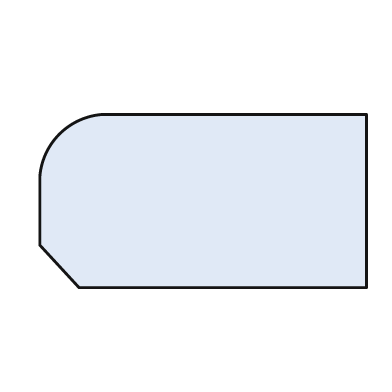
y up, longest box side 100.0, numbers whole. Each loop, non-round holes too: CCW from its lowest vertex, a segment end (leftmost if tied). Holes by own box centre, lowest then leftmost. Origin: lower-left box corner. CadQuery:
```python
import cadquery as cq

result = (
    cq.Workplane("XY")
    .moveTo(12.0, 0.0)
    .lineTo(100.0, 0.0)
    .lineTo(100.0, 53.0)
    .lineTo(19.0, 53.0)
    .threePointArc((6.0, 47.0), (0.0, 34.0))
    .lineTo(0.0, 13.0)
    .close()
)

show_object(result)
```